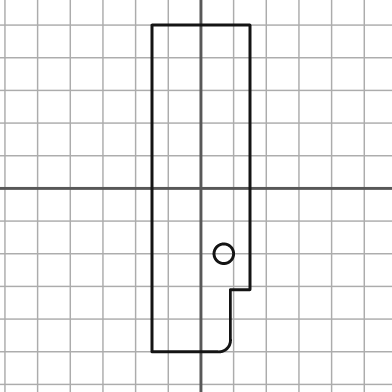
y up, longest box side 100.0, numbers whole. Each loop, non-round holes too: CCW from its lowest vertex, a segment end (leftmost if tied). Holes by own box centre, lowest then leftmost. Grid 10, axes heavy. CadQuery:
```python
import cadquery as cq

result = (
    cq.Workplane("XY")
    .moveTo(-15.0, -50.0)
    .lineTo(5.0, -50.0)
    .threePointArc((8.0, -49.0), (9.0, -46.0))
    .lineTo(9.0, -31.0)
    .lineTo(15.0, -31.0)
    .lineTo(15.0, 50.0)
    .lineTo(-15.0, 50.0)
    .close()
    .moveTo(7.0, -20.0)
    .circle(3.0)
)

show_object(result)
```